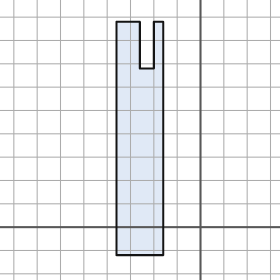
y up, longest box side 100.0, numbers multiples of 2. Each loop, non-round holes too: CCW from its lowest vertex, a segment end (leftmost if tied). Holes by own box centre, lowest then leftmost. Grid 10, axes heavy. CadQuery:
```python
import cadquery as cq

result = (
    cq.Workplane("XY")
    .moveTo(-36.0, -12.0)
    .lineTo(-16.0, -12.0)
    .lineTo(-16.0, 88.0)
    .lineTo(-20.0, 88.0)
    .lineTo(-20.0, 68.0)
    .lineTo(-26.0, 68.0)
    .lineTo(-26.0, 88.0)
    .lineTo(-36.0, 88.0)
    .close()
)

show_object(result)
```